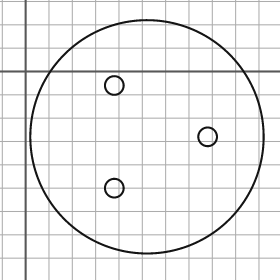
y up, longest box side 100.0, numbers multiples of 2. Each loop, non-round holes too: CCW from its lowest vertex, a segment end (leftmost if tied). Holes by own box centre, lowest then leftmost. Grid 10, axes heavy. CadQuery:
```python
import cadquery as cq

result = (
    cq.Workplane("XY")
    .moveTo(52.0, -28.0)
    .circle(50.0)
    .moveTo(38.0, -50.0)
    .circle(4.0)
    .moveTo(78.0, -28.0)
    .circle(4.0)
    .moveTo(38.0, -6.0)
    .circle(4.0)
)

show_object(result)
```